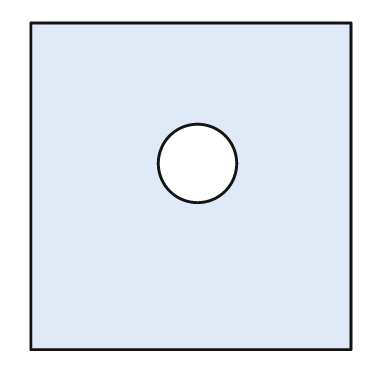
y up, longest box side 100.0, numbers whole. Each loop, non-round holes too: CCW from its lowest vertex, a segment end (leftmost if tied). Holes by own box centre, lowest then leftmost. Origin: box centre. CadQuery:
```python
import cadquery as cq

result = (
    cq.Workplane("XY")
    .moveTo(-49.0, -50.0)
    .lineTo(49.0, -50.0)
    .lineTo(49.0, 50.0)
    .lineTo(-49.0, 50.0)
    .close()
    .moveTo(2.0, 7.0)
    .circle(12.0)
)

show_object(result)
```